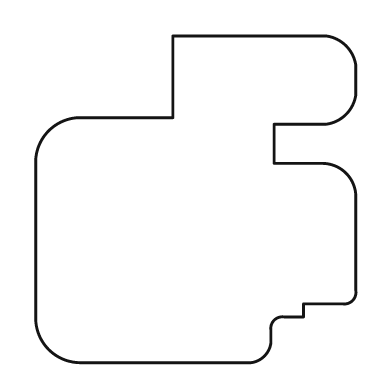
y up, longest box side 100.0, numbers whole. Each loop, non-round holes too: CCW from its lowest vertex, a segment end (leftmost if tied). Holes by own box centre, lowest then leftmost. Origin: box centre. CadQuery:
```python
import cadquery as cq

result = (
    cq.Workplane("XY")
    .moveTo(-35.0, -50.0)
    .lineTo(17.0, -50.0)
    .threePointArc((21.0, -48.0), (23.0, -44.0))
    .lineTo(23.0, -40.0)
    .threePointArc((24.0, -37.0), (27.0, -36.0))
    .lineTo(33.0, -36.0)
    .lineTo(33.0, -32.0)
    .lineTo(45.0, -32.0)
    .threePointArc((48.0, -31.0), (49.0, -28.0))
    .lineTo(49.0, 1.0)
    .threePointArc((46.0, 8.0), (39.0, 11.0))
    .lineTo(24.0, 11.0)
    .lineTo(24.0, 23.0)
    .lineTo(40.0, 23.0)
    .threePointArc((46.0, 26.0), (49.0, 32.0))
    .lineTo(49.0, 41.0)
    .threePointArc((46.0, 47.0), (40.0, 50.0))
    .lineTo(-7.0, 50.0)
    .lineTo(-7.0, 25.0)
    .lineTo(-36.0, 25.0)
    .threePointArc((-45.0, 21.0), (-49.0, 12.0))
    .lineTo(-49.0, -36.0)
    .threePointArc((-45.0, -46.0), (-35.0, -50.0))
    .close()
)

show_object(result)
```